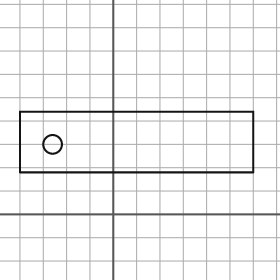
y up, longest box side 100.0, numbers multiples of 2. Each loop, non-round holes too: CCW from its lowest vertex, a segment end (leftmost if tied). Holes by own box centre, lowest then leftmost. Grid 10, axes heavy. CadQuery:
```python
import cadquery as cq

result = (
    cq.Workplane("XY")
    .moveTo(-40.0, 18.0)
    .lineTo(60.0, 18.0)
    .lineTo(60.0, 44.0)
    .lineTo(-40.0, 44.0)
    .close()
    .moveTo(-26.0, 30.0)
    .circle(4.0)
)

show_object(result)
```